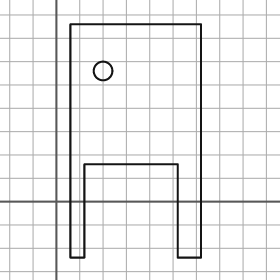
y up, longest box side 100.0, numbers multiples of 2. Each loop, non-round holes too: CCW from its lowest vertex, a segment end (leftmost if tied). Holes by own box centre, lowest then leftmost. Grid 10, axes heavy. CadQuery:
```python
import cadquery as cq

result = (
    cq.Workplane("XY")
    .moveTo(6.0, -24.0)
    .lineTo(12.0, -24.0)
    .lineTo(12.0, 16.0)
    .lineTo(52.0, 16.0)
    .lineTo(52.0, -24.0)
    .lineTo(62.0, -24.0)
    .lineTo(62.0, 76.0)
    .lineTo(6.0, 76.0)
    .close()
    .moveTo(20.0, 56.0)
    .circle(4.0)
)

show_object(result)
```